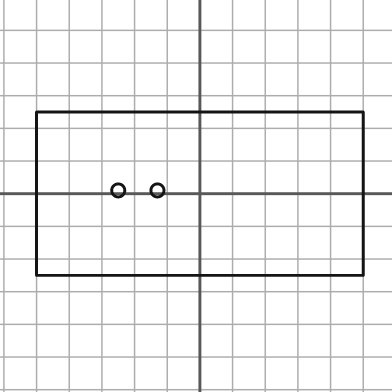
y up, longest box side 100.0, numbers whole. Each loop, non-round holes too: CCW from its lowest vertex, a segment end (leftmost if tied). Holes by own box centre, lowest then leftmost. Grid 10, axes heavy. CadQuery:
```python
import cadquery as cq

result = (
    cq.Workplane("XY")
    .moveTo(-50.0, -25.0)
    .lineTo(50.0, -25.0)
    .lineTo(50.0, 25.0)
    .lineTo(-50.0, 25.0)
    .close()
    .moveTo(-25.0, 1.0)
    .circle(2.0)
    .moveTo(-13.0, 1.0)
    .circle(2.0)
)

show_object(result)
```